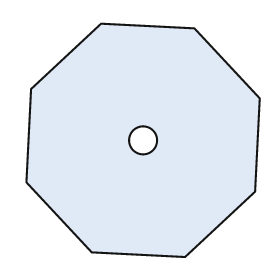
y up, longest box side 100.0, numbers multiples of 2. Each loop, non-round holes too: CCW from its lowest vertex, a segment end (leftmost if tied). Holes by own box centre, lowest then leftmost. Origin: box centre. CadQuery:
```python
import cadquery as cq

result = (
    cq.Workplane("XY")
    .moveTo(18.0, -50.0)
    .lineTo(48.0, -22.0)
    .lineTo(50.0, 18.0)
    .lineTo(22.0, 48.0)
    .lineTo(-18.0, 50.0)
    .lineTo(-48.0, 22.0)
    .lineTo(-50.0, -18.0)
    .lineTo(-22.0, -48.0)
    .close()
    .moveTo(0.0, 0.0)
    .circle(6.0)
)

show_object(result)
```